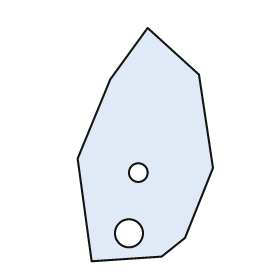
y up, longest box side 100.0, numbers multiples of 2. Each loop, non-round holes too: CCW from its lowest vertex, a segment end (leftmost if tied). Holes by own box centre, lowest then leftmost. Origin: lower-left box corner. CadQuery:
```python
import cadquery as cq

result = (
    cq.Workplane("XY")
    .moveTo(6.0, 0.0)
    .lineTo(36.0, 2.0)
    .lineTo(46.0, 10.0)
    .lineTo(58.0, 40.0)
    .lineTo(52.0, 80.0)
    .lineTo(30.0, 100.0)
    .lineTo(14.0, 78.0)
    .lineTo(0.0, 44.0)
    .close()
    .moveTo(22.0, 12.0)
    .circle(6.0)
    .moveTo(26.0, 38.0)
    .circle(4.0)
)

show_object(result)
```